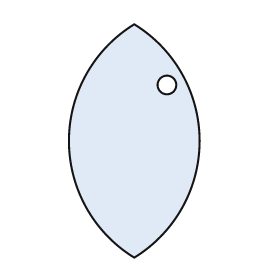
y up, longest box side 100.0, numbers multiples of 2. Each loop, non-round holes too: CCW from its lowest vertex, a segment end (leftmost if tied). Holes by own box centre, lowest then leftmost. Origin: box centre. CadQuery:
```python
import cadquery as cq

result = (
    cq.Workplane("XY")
    .moveTo(0.0, -50.0)
    .threePointArc((28.0, 0.0), (0.0, 50.0))
    .threePointArc((-28.0, 0.0), (0.0, -50.0))
    .close()
    .moveTo(14.0, 24.0)
    .circle(4.0)
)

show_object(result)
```